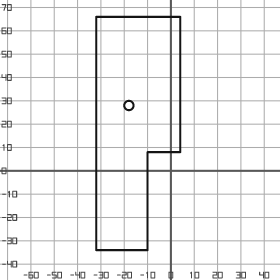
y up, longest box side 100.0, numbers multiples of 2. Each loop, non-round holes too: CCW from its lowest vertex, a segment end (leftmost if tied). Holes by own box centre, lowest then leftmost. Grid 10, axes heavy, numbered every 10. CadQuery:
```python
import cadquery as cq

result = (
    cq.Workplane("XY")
    .moveTo(-32.0, -34.0)
    .lineTo(-10.0, -34.0)
    .lineTo(-10.0, 8.0)
    .lineTo(4.0, 8.0)
    .lineTo(4.0, 66.0)
    .lineTo(-32.0, 66.0)
    .close()
    .moveTo(-18.0, 28.0)
    .circle(2.0)
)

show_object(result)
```